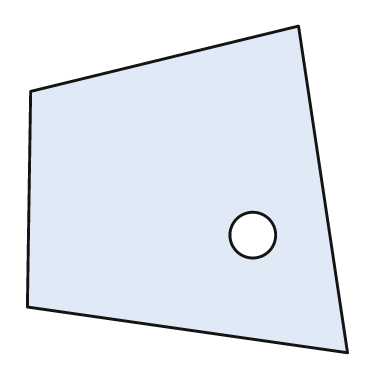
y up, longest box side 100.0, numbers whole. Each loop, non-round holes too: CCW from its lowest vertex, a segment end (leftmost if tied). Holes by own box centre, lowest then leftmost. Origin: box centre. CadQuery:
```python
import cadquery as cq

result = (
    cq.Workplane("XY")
    .moveTo(49.0, -50.0)
    .lineTo(34.0, 50.0)
    .lineTo(-48.0, 30.0)
    .lineTo(-49.0, -36.0)
    .close()
    .moveTo(20.0, -14.0)
    .circle(7.0)
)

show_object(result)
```